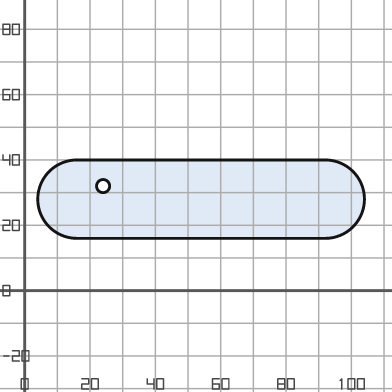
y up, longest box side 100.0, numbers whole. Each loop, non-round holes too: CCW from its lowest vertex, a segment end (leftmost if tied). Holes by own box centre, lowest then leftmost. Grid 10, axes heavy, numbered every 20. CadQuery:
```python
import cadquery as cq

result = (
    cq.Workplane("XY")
    .moveTo(16.0, 16.0)
    .lineTo(92.0, 16.0)
    .threePointArc((104.0, 28.0), (92.0, 40.0))
    .lineTo(16.0, 40.0)
    .threePointArc((4.0, 28.0), (16.0, 16.0))
    .close()
    .moveTo(24.0, 32.0)
    .circle(2.0)
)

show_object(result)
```